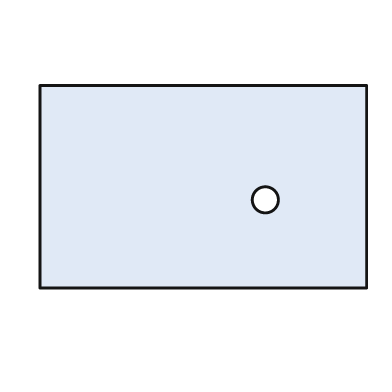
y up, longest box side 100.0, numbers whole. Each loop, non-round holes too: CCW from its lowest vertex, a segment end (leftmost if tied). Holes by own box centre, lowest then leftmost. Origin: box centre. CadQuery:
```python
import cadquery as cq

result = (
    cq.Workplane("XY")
    .moveTo(-50.0, -31.0)
    .lineTo(50.0, -31.0)
    .lineTo(50.0, 31.0)
    .lineTo(-50.0, 31.0)
    .close()
    .moveTo(19.0, -4.0)
    .circle(4.0)
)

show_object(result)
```